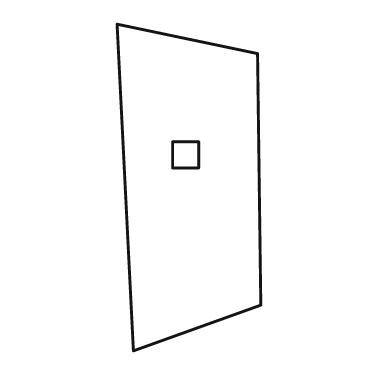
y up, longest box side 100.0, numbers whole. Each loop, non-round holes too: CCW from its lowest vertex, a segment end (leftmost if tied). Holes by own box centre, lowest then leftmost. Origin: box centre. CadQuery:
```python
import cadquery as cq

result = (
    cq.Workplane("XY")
    .moveTo(-17.0, -50.0)
    .lineTo(22.0, -36.0)
    .lineTo(21.0, 41.0)
    .lineTo(-22.0, 50.0)
    .close()
    .moveTo(-5.0, 6.0)
    .lineTo(3.0, 6.0)
    .lineTo(3.0, 14.0)
    .lineTo(-5.0, 14.0)
    .close()
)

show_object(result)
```